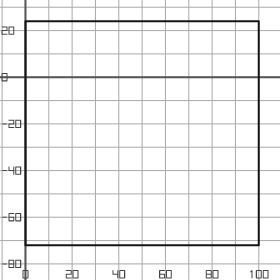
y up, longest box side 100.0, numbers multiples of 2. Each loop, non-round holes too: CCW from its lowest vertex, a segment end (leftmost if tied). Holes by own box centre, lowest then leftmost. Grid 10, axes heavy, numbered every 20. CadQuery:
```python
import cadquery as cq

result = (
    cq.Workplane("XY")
    .moveTo(0.0, -72.0)
    .lineTo(100.0, -72.0)
    .lineTo(100.0, 24.0)
    .lineTo(0.0, 24.0)
    .close()
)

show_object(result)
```